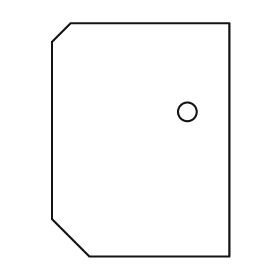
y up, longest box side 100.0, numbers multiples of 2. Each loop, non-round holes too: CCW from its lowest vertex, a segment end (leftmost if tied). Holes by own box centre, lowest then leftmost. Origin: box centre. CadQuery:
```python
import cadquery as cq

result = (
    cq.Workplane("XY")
    .moveTo(-22.0, -50.0)
    .lineTo(38.0, -50.0)
    .lineTo(38.0, 50.0)
    .lineTo(-30.0, 50.0)
    .lineTo(-38.0, 42.0)
    .lineTo(-38.0, -34.0)
    .close()
    .moveTo(20.0, 12.0)
    .circle(4.0)
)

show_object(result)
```